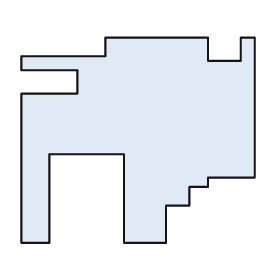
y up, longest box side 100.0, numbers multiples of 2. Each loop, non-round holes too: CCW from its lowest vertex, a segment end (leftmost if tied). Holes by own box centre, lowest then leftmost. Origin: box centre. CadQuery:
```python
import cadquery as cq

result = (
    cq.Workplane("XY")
    .moveTo(-50.0, -44.0)
    .lineTo(-38.0, -44.0)
    .lineTo(-38.0, -6.0)
    .lineTo(-6.0, -6.0)
    .lineTo(-6.0, -44.0)
    .lineTo(12.0, -44.0)
    .lineTo(12.0, -28.0)
    .lineTo(22.0, -28.0)
    .lineTo(22.0, -20.0)
    .lineTo(30.0, -20.0)
    .lineTo(30.0, -16.0)
    .lineTo(50.0, -16.0)
    .lineTo(50.0, 44.0)
    .lineTo(44.0, 44.0)
    .lineTo(44.0, 34.0)
    .lineTo(30.0, 34.0)
    .lineTo(30.0, 44.0)
    .lineTo(-14.0, 44.0)
    .lineTo(-14.0, 36.0)
    .lineTo(-50.0, 36.0)
    .lineTo(-50.0, 30.0)
    .lineTo(-26.0, 30.0)
    .lineTo(-26.0, 20.0)
    .lineTo(-50.0, 20.0)
    .close()
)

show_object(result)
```